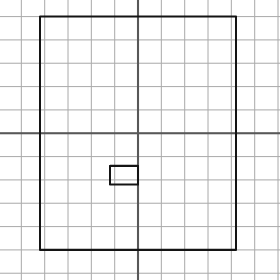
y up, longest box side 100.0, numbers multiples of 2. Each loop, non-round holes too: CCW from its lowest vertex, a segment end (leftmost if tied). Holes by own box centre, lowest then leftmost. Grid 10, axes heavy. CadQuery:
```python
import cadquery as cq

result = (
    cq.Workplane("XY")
    .moveTo(-42.0, -50.0)
    .lineTo(42.0, -50.0)
    .lineTo(42.0, 50.0)
    .lineTo(-42.0, 50.0)
    .close()
    .moveTo(-12.0, -22.0)
    .lineTo(0.0, -22.0)
    .lineTo(0.0, -14.0)
    .lineTo(-12.0, -14.0)
    .close()
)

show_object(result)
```